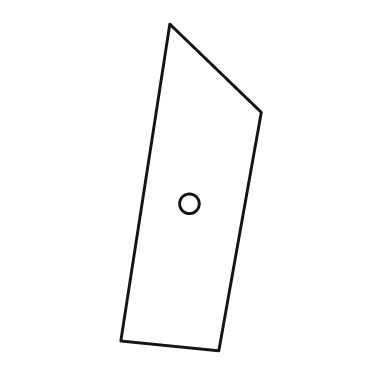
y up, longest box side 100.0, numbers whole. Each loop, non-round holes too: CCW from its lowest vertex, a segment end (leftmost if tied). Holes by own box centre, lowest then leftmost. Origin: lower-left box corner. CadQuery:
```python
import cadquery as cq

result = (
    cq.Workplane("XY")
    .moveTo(30.0, 0.0)
    .lineTo(43.0, 73.0)
    .lineTo(15.0, 100.0)
    .lineTo(0.0, 3.0)
    .close()
    .moveTo(21.0, 45.0)
    .circle(3.0)
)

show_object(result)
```